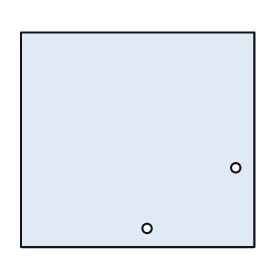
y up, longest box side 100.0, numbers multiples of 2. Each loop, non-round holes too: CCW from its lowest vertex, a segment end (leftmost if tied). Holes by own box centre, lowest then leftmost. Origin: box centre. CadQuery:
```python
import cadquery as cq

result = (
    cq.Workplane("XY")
    .moveTo(-50.0, -46.0)
    .lineTo(50.0, -46.0)
    .lineTo(50.0, 46.0)
    .lineTo(-50.0, 46.0)
    .close()
    .moveTo(4.0, -38.0)
    .circle(2.0)
    .moveTo(42.0, -12.0)
    .circle(2.0)
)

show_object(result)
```